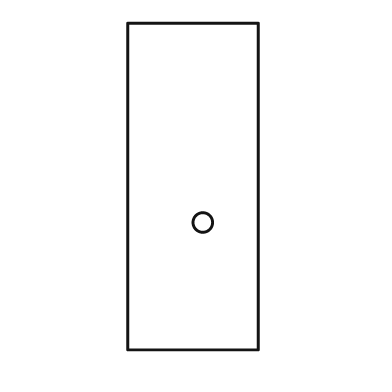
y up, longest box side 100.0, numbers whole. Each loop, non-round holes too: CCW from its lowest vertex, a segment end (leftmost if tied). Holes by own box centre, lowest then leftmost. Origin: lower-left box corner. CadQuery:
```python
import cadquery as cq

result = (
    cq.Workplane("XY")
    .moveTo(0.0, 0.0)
    .lineTo(40.0, 0.0)
    .lineTo(40.0, 100.0)
    .lineTo(0.0, 100.0)
    .close()
    .moveTo(23.0, 39.0)
    .circle(3.0)
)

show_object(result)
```